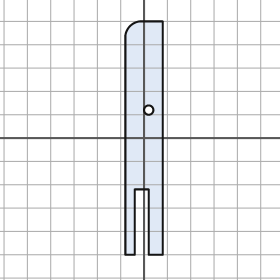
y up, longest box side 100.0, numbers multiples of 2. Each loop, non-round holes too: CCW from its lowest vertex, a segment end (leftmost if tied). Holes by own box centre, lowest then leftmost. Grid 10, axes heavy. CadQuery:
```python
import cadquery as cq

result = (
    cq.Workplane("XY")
    .moveTo(-8.0, -50.0)
    .lineTo(-4.0, -50.0)
    .lineTo(-4.0, -22.0)
    .lineTo(2.0, -22.0)
    .lineTo(2.0, -50.0)
    .lineTo(8.0, -50.0)
    .lineTo(8.0, 50.0)
    .lineTo(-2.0, 50.0)
    .threePointArc((-6.0, 48.0), (-8.0, 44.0))
    .close()
    .moveTo(2.0, 12.0)
    .circle(2.0)
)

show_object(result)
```